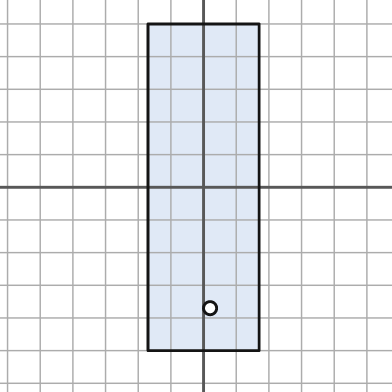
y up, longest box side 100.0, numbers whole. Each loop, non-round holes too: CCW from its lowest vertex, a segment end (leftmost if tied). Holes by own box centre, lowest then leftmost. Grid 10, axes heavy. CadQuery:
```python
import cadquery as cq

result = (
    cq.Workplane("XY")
    .moveTo(-17.0, -50.0)
    .lineTo(17.0, -50.0)
    .lineTo(17.0, 50.0)
    .lineTo(-17.0, 50.0)
    .close()
    .moveTo(2.0, -37.0)
    .circle(2.0)
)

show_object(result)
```